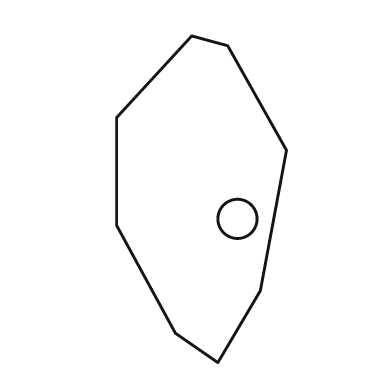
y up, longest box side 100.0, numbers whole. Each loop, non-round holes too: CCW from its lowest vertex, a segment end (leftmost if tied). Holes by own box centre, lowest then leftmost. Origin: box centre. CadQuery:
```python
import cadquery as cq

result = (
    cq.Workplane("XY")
    .moveTo(5.0, -50.0)
    .lineTo(18.0, -28.0)
    .lineTo(26.0, 15.0)
    .lineTo(8.0, 47.0)
    .lineTo(-3.0, 50.0)
    .lineTo(-26.0, 25.0)
    .lineTo(-26.0, -8.0)
    .lineTo(-8.0, -41.0)
    .close()
    .moveTo(11.0, -6.0)
    .circle(6.0)
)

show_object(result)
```